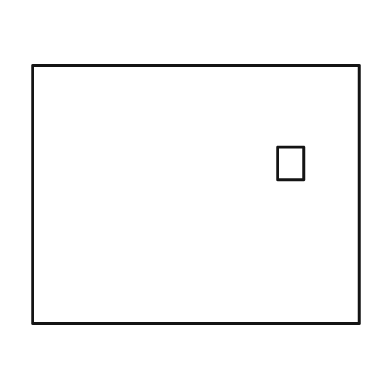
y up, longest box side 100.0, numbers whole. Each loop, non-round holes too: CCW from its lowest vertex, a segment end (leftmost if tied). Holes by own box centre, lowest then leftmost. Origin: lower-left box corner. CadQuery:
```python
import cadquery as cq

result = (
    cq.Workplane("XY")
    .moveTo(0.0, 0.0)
    .lineTo(100.0, 0.0)
    .lineTo(100.0, 79.0)
    .lineTo(0.0, 79.0)
    .close()
    .moveTo(75.0, 44.0)
    .lineTo(83.0, 44.0)
    .lineTo(83.0, 54.0)
    .lineTo(75.0, 54.0)
    .close()
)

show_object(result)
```